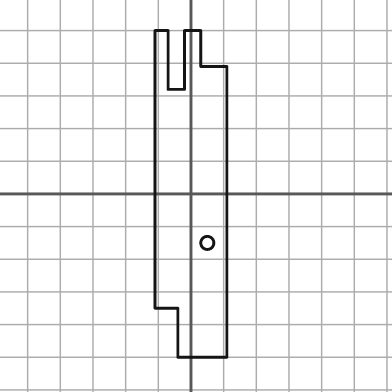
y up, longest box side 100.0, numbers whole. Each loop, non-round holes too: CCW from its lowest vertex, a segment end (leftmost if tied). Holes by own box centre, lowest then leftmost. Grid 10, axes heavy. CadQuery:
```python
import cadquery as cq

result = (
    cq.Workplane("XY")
    .moveTo(-4.0, -50.0)
    .lineTo(11.0, -50.0)
    .lineTo(11.0, 39.0)
    .lineTo(3.0, 39.0)
    .lineTo(3.0, 50.0)
    .lineTo(-2.0, 50.0)
    .lineTo(-2.0, 32.0)
    .lineTo(-7.0, 32.0)
    .lineTo(-7.0, 50.0)
    .lineTo(-11.0, 50.0)
    .lineTo(-11.0, -35.0)
    .lineTo(-4.0, -35.0)
    .close()
    .moveTo(5.0, -15.0)
    .circle(2.0)
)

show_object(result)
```